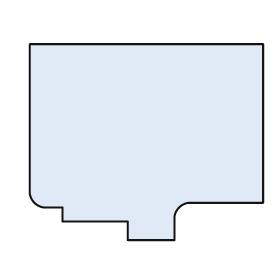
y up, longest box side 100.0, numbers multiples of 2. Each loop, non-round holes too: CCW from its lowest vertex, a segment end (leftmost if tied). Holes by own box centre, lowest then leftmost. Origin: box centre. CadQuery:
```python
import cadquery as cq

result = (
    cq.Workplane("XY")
    .moveTo(-8.0, -42.0)
    .lineTo(12.0, -42.0)
    .lineTo(12.0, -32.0)
    .threePointArc((14.0, -28.0), (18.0, -26.0))
    .lineTo(50.0, -26.0)
    .lineTo(50.0, 42.0)
    .lineTo(-50.0, 42.0)
    .lineTo(-50.0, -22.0)
    .threePointArc((-48.0, -26.0), (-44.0, -28.0))
    .lineTo(-36.0, -28.0)
    .lineTo(-36.0, -34.0)
    .lineTo(-8.0, -34.0)
    .close()
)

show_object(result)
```